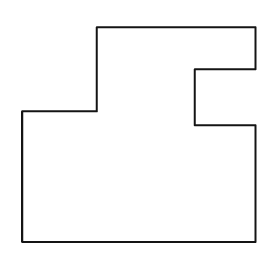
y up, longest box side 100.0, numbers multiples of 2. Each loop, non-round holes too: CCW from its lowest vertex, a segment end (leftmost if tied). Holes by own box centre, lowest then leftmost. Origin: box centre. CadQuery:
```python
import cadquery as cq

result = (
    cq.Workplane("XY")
    .moveTo(-50.0, -46.0)
    .lineTo(50.0, -46.0)
    .lineTo(50.0, 4.0)
    .lineTo(24.0, 4.0)
    .lineTo(24.0, 28.0)
    .lineTo(50.0, 28.0)
    .lineTo(50.0, 46.0)
    .lineTo(-18.0, 46.0)
    .lineTo(-18.0, 10.0)
    .lineTo(-50.0, 10.0)
    .close()
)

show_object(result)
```